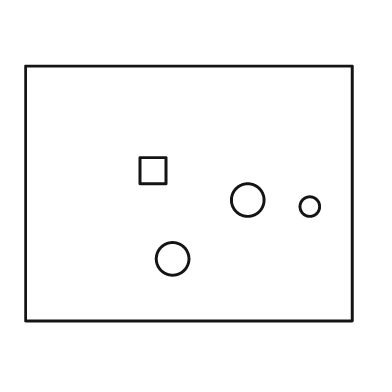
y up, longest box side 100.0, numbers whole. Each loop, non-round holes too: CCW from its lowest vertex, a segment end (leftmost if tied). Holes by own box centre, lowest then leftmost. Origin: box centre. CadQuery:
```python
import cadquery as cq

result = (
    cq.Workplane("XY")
    .moveTo(-50.0, -39.0)
    .lineTo(50.0, -39.0)
    .lineTo(50.0, 39.0)
    .lineTo(-50.0, 39.0)
    .close()
    .moveTo(-5.0, -20.0)
    .circle(5.0)
    .moveTo(37.0, -4.0)
    .circle(3.0)
    .moveTo(18.0, -2.0)
    .circle(5.0)
    .moveTo(-15.0, 3.0)
    .lineTo(-7.0, 3.0)
    .lineTo(-7.0, 11.0)
    .lineTo(-15.0, 11.0)
    .close()
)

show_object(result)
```